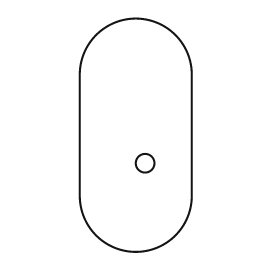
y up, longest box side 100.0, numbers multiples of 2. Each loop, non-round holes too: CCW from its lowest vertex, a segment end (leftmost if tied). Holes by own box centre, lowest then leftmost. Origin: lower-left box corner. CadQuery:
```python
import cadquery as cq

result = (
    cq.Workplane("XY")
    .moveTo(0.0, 24.0)
    .threePointArc((24.0, 0.0), (48.0, 24.0))
    .lineTo(48.0, 76.0)
    .threePointArc((24.0, 100.0), (0.0, 76.0))
    .close()
    .moveTo(28.0, 38.0)
    .circle(4.0)
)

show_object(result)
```